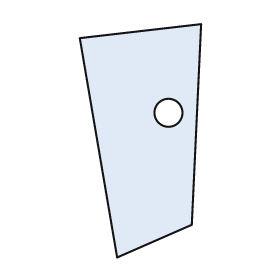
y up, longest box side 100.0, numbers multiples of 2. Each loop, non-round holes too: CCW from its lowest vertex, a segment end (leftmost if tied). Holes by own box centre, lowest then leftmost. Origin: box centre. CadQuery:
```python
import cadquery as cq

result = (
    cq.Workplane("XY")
    .moveTo(-10.0, -50.0)
    .lineTo(22.0, -36.0)
    .lineTo(26.0, 50.0)
    .lineTo(-26.0, 44.0)
    .close()
    .moveTo(12.0, 12.0)
    .circle(6.0)
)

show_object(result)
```